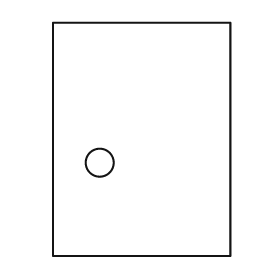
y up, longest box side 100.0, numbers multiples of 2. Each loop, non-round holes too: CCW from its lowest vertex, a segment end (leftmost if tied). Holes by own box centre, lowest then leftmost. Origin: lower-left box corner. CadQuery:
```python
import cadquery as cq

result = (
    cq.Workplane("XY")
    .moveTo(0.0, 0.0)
    .lineTo(76.0, 0.0)
    .lineTo(76.0, 100.0)
    .lineTo(0.0, 100.0)
    .close()
    .moveTo(20.0, 40.0)
    .circle(6.0)
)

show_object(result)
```